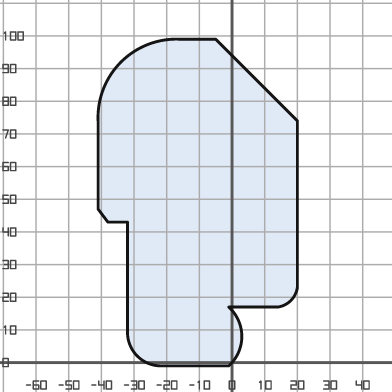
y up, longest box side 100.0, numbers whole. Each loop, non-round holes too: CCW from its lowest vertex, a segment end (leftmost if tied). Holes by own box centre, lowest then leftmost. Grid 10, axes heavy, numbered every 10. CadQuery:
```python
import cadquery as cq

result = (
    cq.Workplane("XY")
    .moveTo(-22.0, -1.0)
    .lineTo(-1.0, -1.0)
    .threePointArc((3.0, 8.0), (-1.0, 17.0))
    .lineTo(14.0, 17.0)
    .threePointArc((18.0, 19.0), (20.0, 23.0))
    .lineTo(20.0, 74.0)
    .lineTo(-5.0, 99.0)
    .lineTo(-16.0, 99.0)
    .threePointArc((-34.0, 92.0), (-41.0, 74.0))
    .lineTo(-41.0, 47.0)
    .lineTo(-38.0, 43.0)
    .lineTo(-32.0, 43.0)
    .lineTo(-32.0, 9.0)
    .threePointArc((-29.0, 2.0), (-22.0, -1.0))
    .close()
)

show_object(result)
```